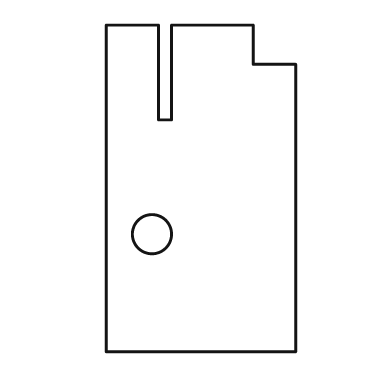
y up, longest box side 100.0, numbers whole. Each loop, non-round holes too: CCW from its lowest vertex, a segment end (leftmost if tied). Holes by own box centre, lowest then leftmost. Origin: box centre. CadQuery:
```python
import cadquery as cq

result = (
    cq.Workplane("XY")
    .moveTo(-29.0, -50.0)
    .lineTo(29.0, -50.0)
    .lineTo(29.0, 38.0)
    .lineTo(16.0, 38.0)
    .lineTo(16.0, 50.0)
    .lineTo(-9.0, 50.0)
    .lineTo(-9.0, 21.0)
    .lineTo(-13.0, 21.0)
    .lineTo(-13.0, 50.0)
    .lineTo(-29.0, 50.0)
    .close()
    .moveTo(-15.0, -14.0)
    .circle(6.0)
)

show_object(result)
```